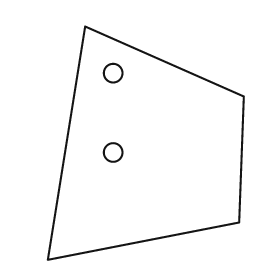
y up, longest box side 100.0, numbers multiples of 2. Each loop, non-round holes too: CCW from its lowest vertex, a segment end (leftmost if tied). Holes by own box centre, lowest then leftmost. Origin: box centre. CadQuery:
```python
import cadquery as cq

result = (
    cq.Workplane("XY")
    .moveTo(-42.0, -50.0)
    .lineTo(40.0, -34.0)
    .lineTo(42.0, 20.0)
    .lineTo(-26.0, 50.0)
    .close()
    .moveTo(-14.0, -4.0)
    .circle(4.0)
    .moveTo(-14.0, 30.0)
    .circle(4.0)
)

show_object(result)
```